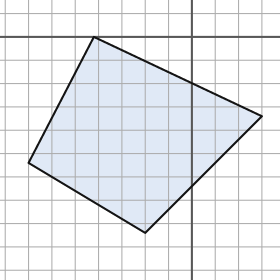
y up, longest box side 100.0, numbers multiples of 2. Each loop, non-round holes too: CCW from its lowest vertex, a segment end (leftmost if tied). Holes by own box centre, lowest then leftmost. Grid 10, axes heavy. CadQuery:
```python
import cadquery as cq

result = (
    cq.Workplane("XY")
    .moveTo(-20.0, -84.0)
    .lineTo(30.0, -34.0)
    .lineTo(-42.0, 0.0)
    .lineTo(-70.0, -54.0)
    .close()
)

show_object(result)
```